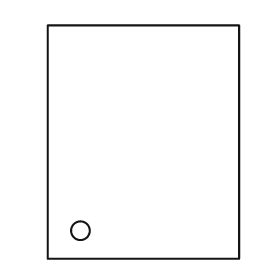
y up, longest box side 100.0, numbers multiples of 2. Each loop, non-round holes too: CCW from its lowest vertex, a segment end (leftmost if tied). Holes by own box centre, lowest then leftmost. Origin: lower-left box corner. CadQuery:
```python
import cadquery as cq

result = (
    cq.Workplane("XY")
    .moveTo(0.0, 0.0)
    .lineTo(82.0, 0.0)
    .lineTo(82.0, 100.0)
    .lineTo(0.0, 100.0)
    .close()
    .moveTo(14.0, 12.0)
    .circle(4.0)
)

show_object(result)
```